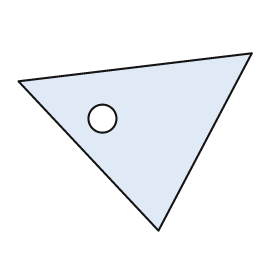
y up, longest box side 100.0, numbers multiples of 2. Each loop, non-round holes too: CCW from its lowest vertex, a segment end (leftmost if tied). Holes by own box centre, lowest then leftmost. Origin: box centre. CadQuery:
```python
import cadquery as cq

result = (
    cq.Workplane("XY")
    .moveTo(10.0, -38.0)
    .lineTo(50.0, 38.0)
    .lineTo(-50.0, 26.0)
    .close()
    .moveTo(-14.0, 10.0)
    .circle(6.0)
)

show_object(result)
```